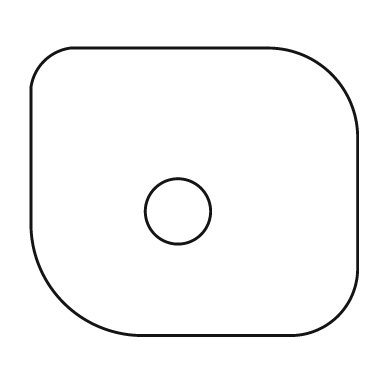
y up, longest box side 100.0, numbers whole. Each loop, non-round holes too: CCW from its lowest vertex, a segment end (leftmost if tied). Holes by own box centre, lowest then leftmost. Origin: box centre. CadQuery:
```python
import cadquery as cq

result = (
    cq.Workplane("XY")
    .moveTo(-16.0, -44.0)
    .lineTo(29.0, -44.0)
    .threePointArc((44.0, -38.0), (50.0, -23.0))
    .lineTo(50.0, 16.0)
    .threePointArc((42.0, 36.0), (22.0, 44.0))
    .lineTo(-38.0, 44.0)
    .threePointArc((-46.0, 40.0), (-50.0, 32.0))
    .lineTo(-50.0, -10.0)
    .threePointArc((-40.0, -34.0), (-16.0, -44.0))
    .close()
    .moveTo(-5.0, -6.0)
    .circle(10.0)
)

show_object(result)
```